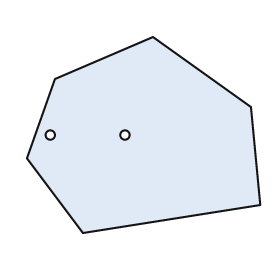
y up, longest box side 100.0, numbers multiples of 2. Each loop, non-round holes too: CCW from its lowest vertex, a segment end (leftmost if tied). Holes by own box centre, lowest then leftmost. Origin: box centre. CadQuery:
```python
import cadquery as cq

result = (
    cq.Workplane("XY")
    .moveTo(-26.0, -42.0)
    .lineTo(50.0, -30.0)
    .lineTo(46.0, 12.0)
    .lineTo(4.0, 42.0)
    .lineTo(-38.0, 24.0)
    .lineTo(-50.0, -10.0)
    .close()
    .moveTo(-40.0, 0.0)
    .circle(2.0)
    .moveTo(-8.0, 0.0)
    .circle(2.0)
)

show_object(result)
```